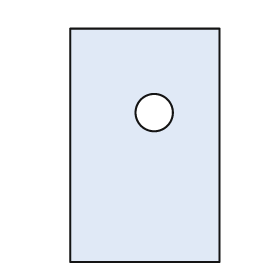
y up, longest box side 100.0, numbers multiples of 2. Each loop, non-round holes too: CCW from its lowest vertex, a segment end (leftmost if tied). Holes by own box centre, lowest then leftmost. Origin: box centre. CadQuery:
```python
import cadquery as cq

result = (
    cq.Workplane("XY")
    .moveTo(-32.0, -50.0)
    .lineTo(32.0, -50.0)
    .lineTo(32.0, 50.0)
    .lineTo(-32.0, 50.0)
    .close()
    .moveTo(4.0, 14.0)
    .circle(8.0)
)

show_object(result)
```